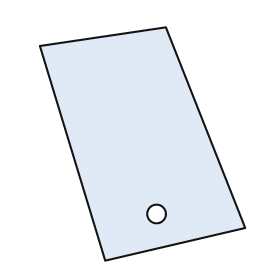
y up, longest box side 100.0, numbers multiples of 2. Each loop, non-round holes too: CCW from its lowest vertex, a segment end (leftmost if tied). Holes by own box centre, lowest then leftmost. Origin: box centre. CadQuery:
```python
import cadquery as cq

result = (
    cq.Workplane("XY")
    .moveTo(-16.0, -50.0)
    .lineTo(44.0, -36.0)
    .lineTo(10.0, 50.0)
    .lineTo(-44.0, 42.0)
    .close()
    .moveTo(6.0, -30.0)
    .circle(4.0)
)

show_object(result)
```